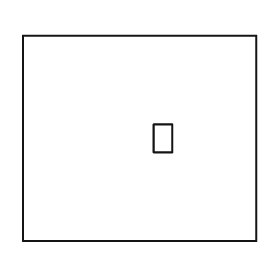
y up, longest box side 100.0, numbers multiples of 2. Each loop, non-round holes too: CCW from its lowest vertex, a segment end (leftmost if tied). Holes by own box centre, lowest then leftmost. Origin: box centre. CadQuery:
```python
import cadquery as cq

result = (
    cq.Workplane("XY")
    .moveTo(-50.0, -44.0)
    .lineTo(50.0, -44.0)
    .lineTo(50.0, 44.0)
    .lineTo(-50.0, 44.0)
    .close()
    .moveTo(6.0, -6.0)
    .lineTo(14.0, -6.0)
    .lineTo(14.0, 6.0)
    .lineTo(6.0, 6.0)
    .close()
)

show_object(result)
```